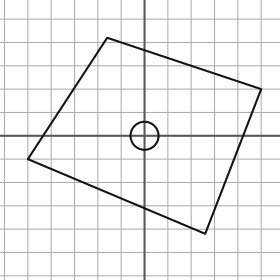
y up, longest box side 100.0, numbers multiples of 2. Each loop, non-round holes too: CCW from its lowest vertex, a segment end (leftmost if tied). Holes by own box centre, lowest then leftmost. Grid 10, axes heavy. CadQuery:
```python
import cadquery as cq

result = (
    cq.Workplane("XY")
    .moveTo(26.0, -42.0)
    .lineTo(50.0, 20.0)
    .lineTo(-16.0, 42.0)
    .lineTo(-50.0, -10.0)
    .close()
    .moveTo(0.0, 0.0)
    .circle(6.0)
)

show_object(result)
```